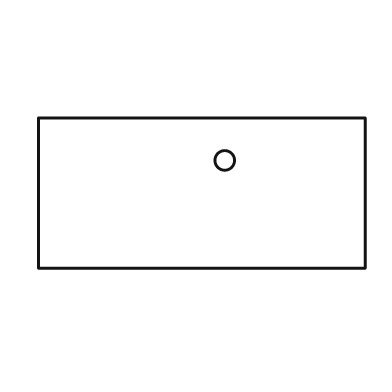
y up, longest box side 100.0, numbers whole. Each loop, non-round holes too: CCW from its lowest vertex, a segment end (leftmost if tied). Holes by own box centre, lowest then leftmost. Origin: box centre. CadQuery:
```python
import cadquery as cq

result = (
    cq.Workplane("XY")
    .moveTo(-50.0, -23.0)
    .lineTo(50.0, -23.0)
    .lineTo(50.0, 23.0)
    .lineTo(-50.0, 23.0)
    .close()
    .moveTo(7.0, 10.0)
    .circle(3.0)
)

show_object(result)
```